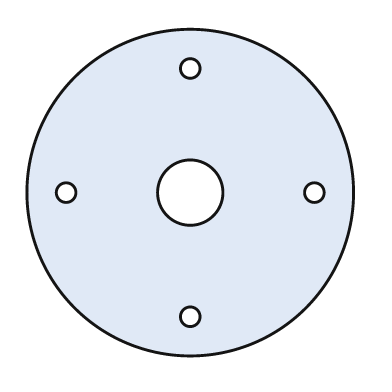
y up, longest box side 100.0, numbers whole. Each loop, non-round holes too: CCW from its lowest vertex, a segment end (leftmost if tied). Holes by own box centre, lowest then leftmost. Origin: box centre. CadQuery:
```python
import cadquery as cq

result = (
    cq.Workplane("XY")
    .moveTo(0.0, 0.0)
    .circle(50.0)
    .moveTo(0.0, -38.0)
    .circle(3.0)
    .moveTo(-38.0, 0.0)
    .circle(3.0)
    .moveTo(0.0, 0.0)
    .circle(10.0)
    .moveTo(38.0, 0.0)
    .circle(3.0)
    .moveTo(0.0, 38.0)
    .circle(3.0)
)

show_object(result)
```